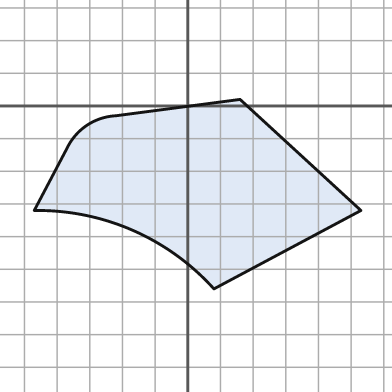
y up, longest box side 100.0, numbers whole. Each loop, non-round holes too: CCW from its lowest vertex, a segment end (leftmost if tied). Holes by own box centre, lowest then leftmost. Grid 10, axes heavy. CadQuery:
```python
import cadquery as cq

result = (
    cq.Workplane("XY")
    .moveTo(8.0, -56.0)
    .lineTo(53.0, -32.0)
    .lineTo(16.0, 2.0)
    .lineTo(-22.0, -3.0)
    .threePointArc((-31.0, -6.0), (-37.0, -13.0))
    .lineTo(-47.0, -32.0)
    .threePointArc((-17.0, -38.0), (8.0, -56.0))
    .close()
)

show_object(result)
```